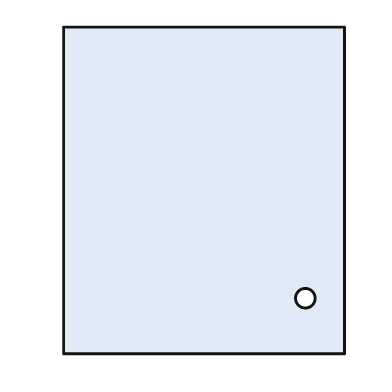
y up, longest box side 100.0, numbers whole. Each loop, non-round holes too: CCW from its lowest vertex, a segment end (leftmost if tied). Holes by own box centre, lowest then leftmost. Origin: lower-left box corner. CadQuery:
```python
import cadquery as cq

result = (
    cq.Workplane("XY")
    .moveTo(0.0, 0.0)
    .lineTo(86.0, 0.0)
    .lineTo(86.0, 100.0)
    .lineTo(0.0, 100.0)
    .close()
    .moveTo(74.0, 17.0)
    .circle(3.0)
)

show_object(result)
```